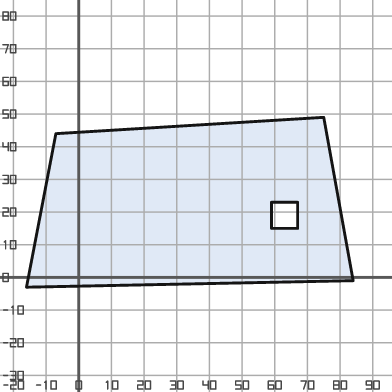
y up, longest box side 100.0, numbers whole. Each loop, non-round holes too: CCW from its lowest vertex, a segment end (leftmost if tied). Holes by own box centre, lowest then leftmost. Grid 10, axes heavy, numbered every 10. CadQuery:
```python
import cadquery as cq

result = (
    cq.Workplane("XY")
    .moveTo(-16.0, -3.0)
    .lineTo(84.0, -1.0)
    .lineTo(75.0, 49.0)
    .lineTo(-7.0, 44.0)
    .close()
    .moveTo(59.0, 15.0)
    .lineTo(67.0, 15.0)
    .lineTo(67.0, 23.0)
    .lineTo(59.0, 23.0)
    .close()
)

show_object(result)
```